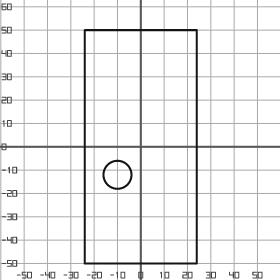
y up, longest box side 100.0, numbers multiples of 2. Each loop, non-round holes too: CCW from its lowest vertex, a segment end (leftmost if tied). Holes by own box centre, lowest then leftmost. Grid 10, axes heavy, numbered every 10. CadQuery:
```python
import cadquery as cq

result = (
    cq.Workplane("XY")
    .moveTo(-24.0, -50.0)
    .lineTo(24.0, -50.0)
    .lineTo(24.0, 50.0)
    .lineTo(-24.0, 50.0)
    .close()
    .moveTo(-10.0, -12.0)
    .circle(6.0)
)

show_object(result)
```